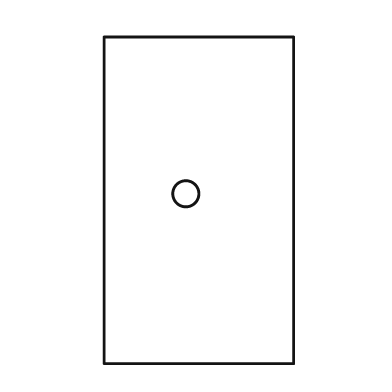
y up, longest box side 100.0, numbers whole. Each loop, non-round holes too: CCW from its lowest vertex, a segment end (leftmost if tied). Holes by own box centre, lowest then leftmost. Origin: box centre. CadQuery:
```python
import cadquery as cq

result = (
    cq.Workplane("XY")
    .moveTo(-29.0, -50.0)
    .lineTo(29.0, -50.0)
    .lineTo(29.0, 50.0)
    .lineTo(-29.0, 50.0)
    .close()
    .moveTo(-4.0, 2.0)
    .circle(4.0)
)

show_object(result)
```